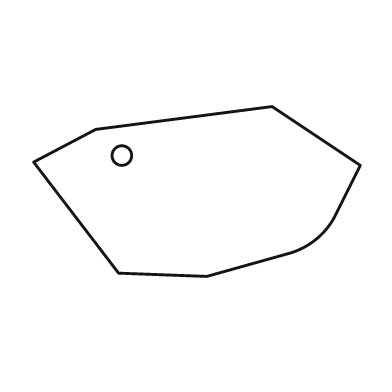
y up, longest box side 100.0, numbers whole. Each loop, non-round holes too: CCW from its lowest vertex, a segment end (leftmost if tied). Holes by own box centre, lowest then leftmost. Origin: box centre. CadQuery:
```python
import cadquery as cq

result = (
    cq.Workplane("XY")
    .moveTo(3.0, -26.0)
    .lineTo(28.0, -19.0)
    .threePointArc((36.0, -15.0), (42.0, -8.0))
    .lineTo(50.0, 8.0)
    .lineTo(23.0, 26.0)
    .lineTo(-31.0, 19.0)
    .lineTo(-50.0, 9.0)
    .lineTo(-24.0, -25.0)
    .close()
    .moveTo(-23.0, 11.0)
    .circle(3.0)
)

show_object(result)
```